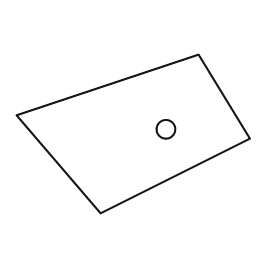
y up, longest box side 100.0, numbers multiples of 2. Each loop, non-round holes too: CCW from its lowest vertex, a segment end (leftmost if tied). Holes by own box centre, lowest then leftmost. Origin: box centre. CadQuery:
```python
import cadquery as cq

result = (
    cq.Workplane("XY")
    .moveTo(-14.0, -34.0)
    .lineTo(50.0, -2.0)
    .lineTo(28.0, 34.0)
    .lineTo(-50.0, 8.0)
    .close()
    .moveTo(14.0, 2.0)
    .circle(4.0)
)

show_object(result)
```